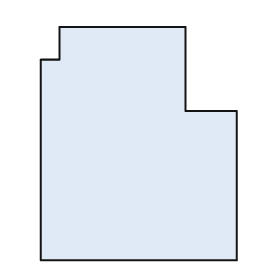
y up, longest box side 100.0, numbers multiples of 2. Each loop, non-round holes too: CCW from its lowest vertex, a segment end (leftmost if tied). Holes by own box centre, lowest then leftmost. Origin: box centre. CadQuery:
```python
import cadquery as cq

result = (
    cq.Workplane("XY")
    .moveTo(-42.0, -50.0)
    .lineTo(42.0, -50.0)
    .lineTo(42.0, 14.0)
    .lineTo(20.0, 14.0)
    .lineTo(20.0, 50.0)
    .lineTo(-34.0, 50.0)
    .lineTo(-34.0, 36.0)
    .lineTo(-42.0, 36.0)
    .close()
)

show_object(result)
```